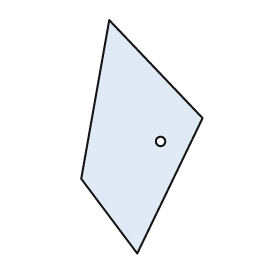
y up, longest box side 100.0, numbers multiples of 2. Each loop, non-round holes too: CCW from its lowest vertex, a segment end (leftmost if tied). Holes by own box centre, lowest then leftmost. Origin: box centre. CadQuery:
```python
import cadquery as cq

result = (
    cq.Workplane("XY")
    .moveTo(-2.0, -50.0)
    .lineTo(26.0, 8.0)
    .lineTo(-14.0, 50.0)
    .lineTo(-26.0, -18.0)
    .close()
    .moveTo(8.0, -2.0)
    .circle(2.0)
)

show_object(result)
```